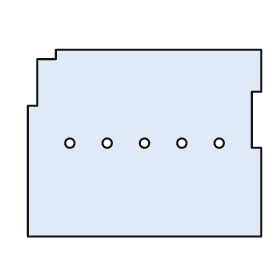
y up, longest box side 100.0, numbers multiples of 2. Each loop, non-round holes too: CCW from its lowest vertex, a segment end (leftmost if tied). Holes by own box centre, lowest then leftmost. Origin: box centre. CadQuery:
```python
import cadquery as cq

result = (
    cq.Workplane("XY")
    .moveTo(-50.0, -40.0)
    .lineTo(50.0, -40.0)
    .lineTo(50.0, -2.0)
    .lineTo(46.0, -2.0)
    .lineTo(46.0, 22.0)
    .lineTo(50.0, 22.0)
    .lineTo(50.0, 40.0)
    .lineTo(-38.0, 40.0)
    .lineTo(-38.0, 36.0)
    .lineTo(-46.0, 36.0)
    .lineTo(-46.0, 16.0)
    .lineTo(-50.0, 16.0)
    .close()
    .moveTo(-32.0, 0.0)
    .circle(2.0)
    .moveTo(-16.0, 0.0)
    .circle(2.0)
    .moveTo(0.0, 0.0)
    .circle(2.0)
    .moveTo(16.0, 0.0)
    .circle(2.0)
    .moveTo(32.0, 0.0)
    .circle(2.0)
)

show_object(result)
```